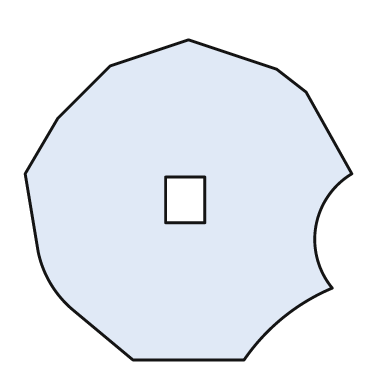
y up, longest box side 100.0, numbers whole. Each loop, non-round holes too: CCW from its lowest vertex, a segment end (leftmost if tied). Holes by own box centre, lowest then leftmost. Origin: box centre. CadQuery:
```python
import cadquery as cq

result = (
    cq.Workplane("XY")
    .moveTo(-17.0, -49.0)
    .lineTo(17.0, -49.0)
    .threePointArc((29.0, -36.0), (44.0, -27.0))
    .threePointArc((39.0, -8.0), (50.0, 8.0))
    .lineTo(36.0, 33.0)
    .lineTo(27.0, 40.0)
    .lineTo(0.0, 49.0)
    .lineTo(-24.0, 41.0)
    .lineTo(-40.0, 25.0)
    .lineTo(-50.0, 8.0)
    .lineTo(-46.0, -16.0)
    .threePointArc((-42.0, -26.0), (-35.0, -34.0))
    .close()
    .moveTo(-7.0, -7.0)
    .lineTo(5.0, -7.0)
    .lineTo(5.0, 7.0)
    .lineTo(-7.0, 7.0)
    .close()
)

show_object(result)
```